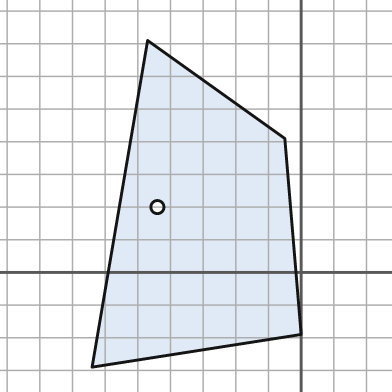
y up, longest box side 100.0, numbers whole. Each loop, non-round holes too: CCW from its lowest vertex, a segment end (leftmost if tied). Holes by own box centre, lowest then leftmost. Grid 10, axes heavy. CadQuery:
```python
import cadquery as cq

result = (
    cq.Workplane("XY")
    .moveTo(-64.0, -29.0)
    .lineTo(0.0, -19.0)
    .lineTo(-5.0, 41.0)
    .lineTo(-47.0, 71.0)
    .close()
    .moveTo(-44.0, 20.0)
    .circle(2.0)
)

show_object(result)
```